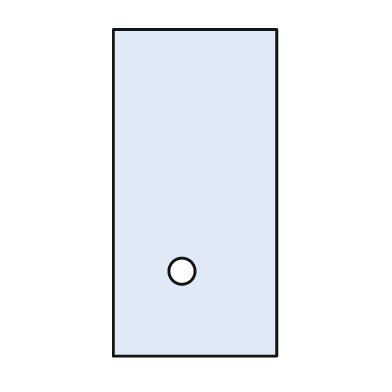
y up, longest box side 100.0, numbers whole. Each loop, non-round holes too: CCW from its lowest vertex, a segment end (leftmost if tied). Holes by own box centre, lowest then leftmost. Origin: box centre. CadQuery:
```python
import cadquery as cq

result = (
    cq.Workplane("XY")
    .moveTo(-25.0, -50.0)
    .lineTo(25.0, -50.0)
    .lineTo(25.0, 50.0)
    .lineTo(-25.0, 50.0)
    .close()
    .moveTo(-4.0, -24.0)
    .circle(4.0)
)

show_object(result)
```